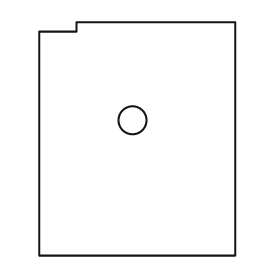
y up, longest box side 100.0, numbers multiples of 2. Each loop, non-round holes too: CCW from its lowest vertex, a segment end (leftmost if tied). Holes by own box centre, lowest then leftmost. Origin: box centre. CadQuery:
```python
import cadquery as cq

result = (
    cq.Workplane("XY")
    .moveTo(-42.0, -50.0)
    .lineTo(42.0, -50.0)
    .lineTo(42.0, 50.0)
    .lineTo(-26.0, 50.0)
    .lineTo(-26.0, 46.0)
    .lineTo(-42.0, 46.0)
    .close()
    .moveTo(-2.0, 8.0)
    .circle(6.0)
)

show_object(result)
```